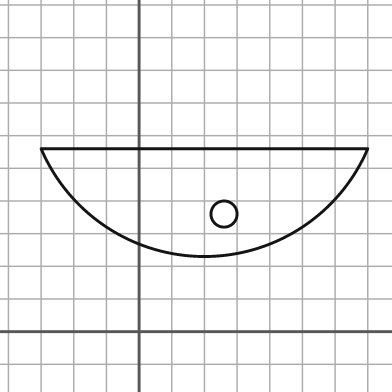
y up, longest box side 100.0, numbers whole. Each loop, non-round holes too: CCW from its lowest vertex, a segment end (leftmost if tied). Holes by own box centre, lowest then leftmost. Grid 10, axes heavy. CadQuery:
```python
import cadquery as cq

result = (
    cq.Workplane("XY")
    .moveTo(-30.0, 56.0)
    .threePointArc((20.0, 23.0), (70.0, 56.0))
    .close()
    .moveTo(26.0, 36.0)
    .circle(4.0)
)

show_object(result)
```